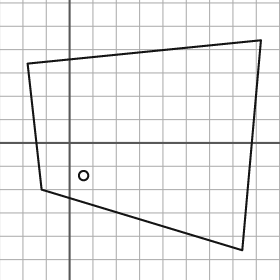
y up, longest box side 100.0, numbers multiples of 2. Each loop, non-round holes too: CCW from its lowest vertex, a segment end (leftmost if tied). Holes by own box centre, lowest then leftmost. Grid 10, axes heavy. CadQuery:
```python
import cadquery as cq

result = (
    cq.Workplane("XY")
    .moveTo(74.0, -46.0)
    .lineTo(82.0, 44.0)
    .lineTo(-18.0, 34.0)
    .lineTo(-12.0, -20.0)
    .close()
    .moveTo(6.0, -14.0)
    .circle(2.0)
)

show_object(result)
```